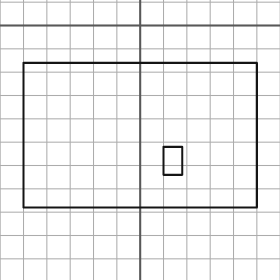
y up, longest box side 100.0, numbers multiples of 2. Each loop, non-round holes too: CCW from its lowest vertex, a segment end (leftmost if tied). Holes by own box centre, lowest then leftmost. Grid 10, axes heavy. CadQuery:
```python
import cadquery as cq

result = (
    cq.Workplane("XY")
    .moveTo(-50.0, -78.0)
    .lineTo(50.0, -78.0)
    .lineTo(50.0, -16.0)
    .lineTo(-50.0, -16.0)
    .close()
    .moveTo(10.0, -64.0)
    .lineTo(18.0, -64.0)
    .lineTo(18.0, -52.0)
    .lineTo(10.0, -52.0)
    .close()
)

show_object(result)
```